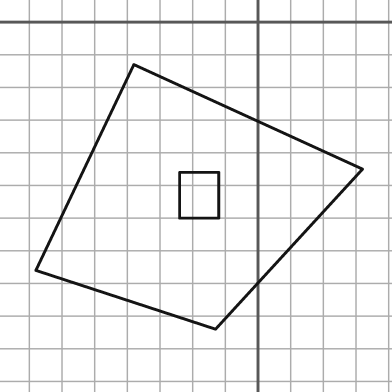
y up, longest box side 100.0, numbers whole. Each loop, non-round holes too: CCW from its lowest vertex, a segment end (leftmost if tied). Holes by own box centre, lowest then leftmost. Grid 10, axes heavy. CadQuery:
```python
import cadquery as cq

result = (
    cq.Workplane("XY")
    .moveTo(-13.0, -94.0)
    .lineTo(32.0, -45.0)
    .lineTo(-38.0, -13.0)
    .lineTo(-68.0, -76.0)
    .close()
    .moveTo(-24.0, -60.0)
    .lineTo(-12.0, -60.0)
    .lineTo(-12.0, -46.0)
    .lineTo(-24.0, -46.0)
    .close()
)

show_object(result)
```